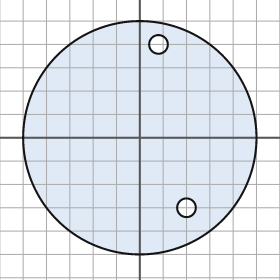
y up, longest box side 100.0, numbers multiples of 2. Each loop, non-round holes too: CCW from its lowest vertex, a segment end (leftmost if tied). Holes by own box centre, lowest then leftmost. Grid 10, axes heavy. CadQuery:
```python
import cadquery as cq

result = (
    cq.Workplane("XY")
    .moveTo(0.0, 0.0)
    .circle(50.0)
    .moveTo(20.0, -30.0)
    .circle(4.0)
    .moveTo(8.0, 40.0)
    .circle(4.0)
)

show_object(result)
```